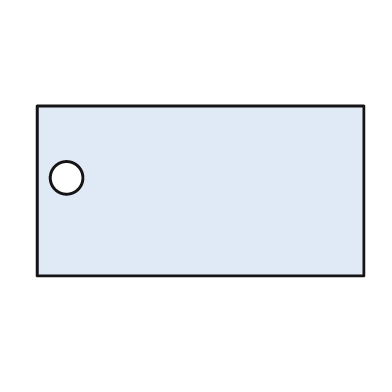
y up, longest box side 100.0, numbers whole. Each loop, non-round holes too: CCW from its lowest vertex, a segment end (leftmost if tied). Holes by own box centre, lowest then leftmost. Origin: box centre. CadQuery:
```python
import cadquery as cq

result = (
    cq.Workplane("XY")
    .moveTo(-50.0, -26.0)
    .lineTo(50.0, -26.0)
    .lineTo(50.0, 26.0)
    .lineTo(-50.0, 26.0)
    .close()
    .moveTo(-41.0, 4.0)
    .circle(5.0)
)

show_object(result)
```